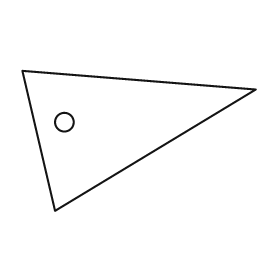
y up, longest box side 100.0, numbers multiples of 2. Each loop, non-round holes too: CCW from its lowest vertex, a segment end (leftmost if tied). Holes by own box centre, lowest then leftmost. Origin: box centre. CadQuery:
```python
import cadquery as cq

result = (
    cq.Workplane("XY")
    .moveTo(-36.0, -30.0)
    .lineTo(50.0, 22.0)
    .lineTo(-50.0, 30.0)
    .close()
    .moveTo(-32.0, 8.0)
    .circle(4.0)
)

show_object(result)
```